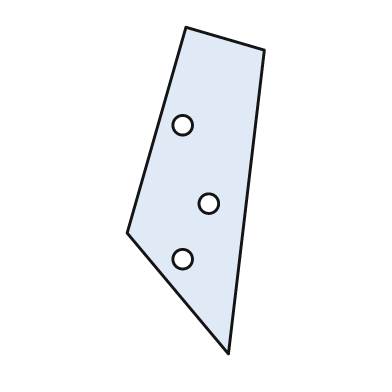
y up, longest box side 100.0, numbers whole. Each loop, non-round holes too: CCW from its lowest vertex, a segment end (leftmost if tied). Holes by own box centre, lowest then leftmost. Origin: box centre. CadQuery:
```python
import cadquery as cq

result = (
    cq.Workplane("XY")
    .moveTo(10.0, -50.0)
    .lineTo(21.0, 43.0)
    .lineTo(-3.0, 50.0)
    .lineTo(-21.0, -13.0)
    .close()
    .moveTo(-4.0, -21.0)
    .circle(3.0)
    .moveTo(4.0, -4.0)
    .circle(3.0)
    .moveTo(-4.0, 20.0)
    .circle(3.0)
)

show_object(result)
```